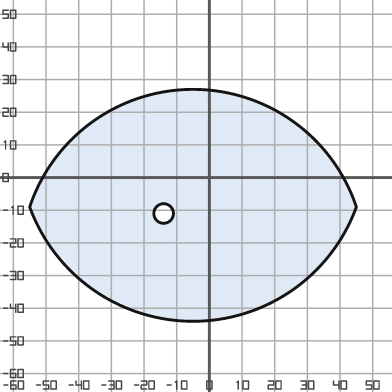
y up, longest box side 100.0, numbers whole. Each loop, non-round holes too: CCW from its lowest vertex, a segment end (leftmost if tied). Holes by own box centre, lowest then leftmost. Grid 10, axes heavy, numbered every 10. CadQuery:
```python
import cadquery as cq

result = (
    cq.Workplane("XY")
    .moveTo(-55.0, -9.0)
    .threePointArc((-5.0, -44.0), (45.0, -9.0))
    .threePointArc((-5.0, 27.0), (-55.0, -9.0))
    .close()
    .moveTo(-14.0, -11.0)
    .circle(3.0)
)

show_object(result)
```